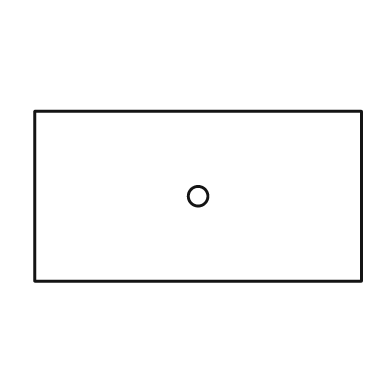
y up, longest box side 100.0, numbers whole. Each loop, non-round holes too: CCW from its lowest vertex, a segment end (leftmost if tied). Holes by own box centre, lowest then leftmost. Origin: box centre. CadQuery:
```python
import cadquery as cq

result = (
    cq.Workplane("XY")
    .moveTo(-50.0, -26.0)
    .lineTo(50.0, -26.0)
    .lineTo(50.0, 26.0)
    .lineTo(-50.0, 26.0)
    .close()
    .moveTo(0.0, 0.0)
    .circle(3.0)
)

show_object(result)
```